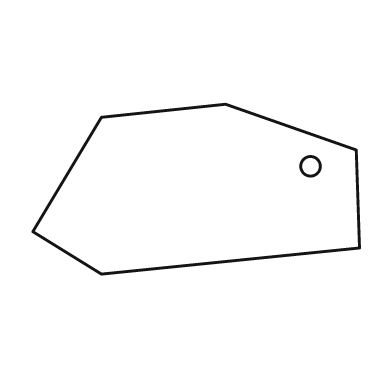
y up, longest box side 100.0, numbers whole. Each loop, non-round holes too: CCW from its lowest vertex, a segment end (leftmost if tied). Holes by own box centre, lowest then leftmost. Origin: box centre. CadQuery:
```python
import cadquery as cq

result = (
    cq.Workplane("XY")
    .moveTo(-29.0, -26.0)
    .lineTo(50.0, -18.0)
    .lineTo(49.0, 12.0)
    .lineTo(9.0, 26.0)
    .lineTo(-29.0, 22.0)
    .lineTo(-50.0, -13.0)
    .close()
    .moveTo(35.0, 7.0)
    .circle(3.0)
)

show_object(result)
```